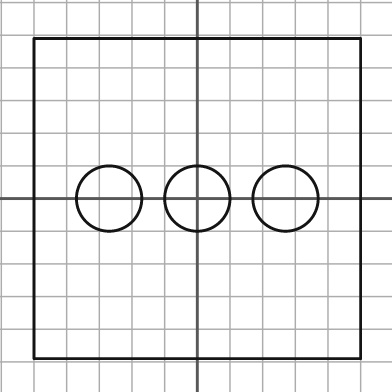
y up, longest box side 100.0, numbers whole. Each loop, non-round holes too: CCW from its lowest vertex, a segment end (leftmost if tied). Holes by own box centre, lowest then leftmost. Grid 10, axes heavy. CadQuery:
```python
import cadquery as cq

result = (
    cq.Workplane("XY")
    .moveTo(-50.0, -49.0)
    .lineTo(50.0, -49.0)
    .lineTo(50.0, 49.0)
    .lineTo(-50.0, 49.0)
    .close()
    .moveTo(-27.0, 0.0)
    .circle(10.0)
    .moveTo(0.0, 0.0)
    .circle(10.0)
    .moveTo(27.0, 0.0)
    .circle(10.0)
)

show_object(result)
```